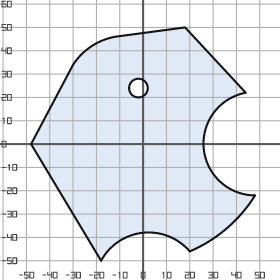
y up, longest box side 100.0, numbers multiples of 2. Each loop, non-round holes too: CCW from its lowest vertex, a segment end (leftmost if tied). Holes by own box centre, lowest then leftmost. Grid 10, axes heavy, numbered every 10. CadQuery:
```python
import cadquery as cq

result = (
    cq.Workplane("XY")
    .moveTo(-18.0, -50.0)
    .threePointArc((0.0, -38.0), (20.0, -46.0))
    .threePointArc((36.0, -36.0), (48.0, -22.0))
    .threePointArc((26.0, -2.0), (44.0, 22.0))
    .lineTo(18.0, 50.0)
    .lineTo(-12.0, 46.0)
    .threePointArc((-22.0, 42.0), (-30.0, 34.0))
    .lineTo(-48.0, 0.0)
    .close()
    .moveTo(-2.0, 24.0)
    .circle(4.0)
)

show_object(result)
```